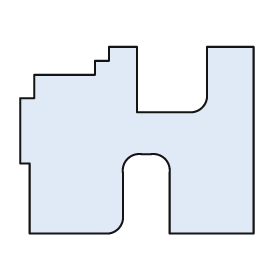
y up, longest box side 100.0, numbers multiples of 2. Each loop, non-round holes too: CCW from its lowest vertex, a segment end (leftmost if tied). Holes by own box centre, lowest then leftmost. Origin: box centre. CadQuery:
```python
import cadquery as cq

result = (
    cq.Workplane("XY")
    .moveTo(-46.0, -40.0)
    .lineTo(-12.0, -40.0)
    .threePointArc((-8.0, -38.0), (-6.0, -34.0))
    .lineTo(-6.0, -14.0)
    .threePointArc((-4.0, -8.0), (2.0, -6.0))
    .lineTo(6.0, -6.0)
    .threePointArc((12.0, -8.0), (14.0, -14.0))
    .lineTo(14.0, -40.0)
    .lineTo(50.0, -40.0)
    .lineTo(50.0, 40.0)
    .lineTo(30.0, 40.0)
    .lineTo(30.0, 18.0)
    .threePointArc((28.0, 14.0), (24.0, 12.0))
    .lineTo(0.0, 12.0)
    .lineTo(0.0, 40.0)
    .lineTo(-12.0, 40.0)
    .lineTo(-12.0, 34.0)
    .lineTo(-18.0, 34.0)
    .lineTo(-18.0, 28.0)
    .lineTo(-44.0, 28.0)
    .lineTo(-44.0, 18.0)
    .lineTo(-50.0, 18.0)
    .lineTo(-50.0, -10.0)
    .lineTo(-46.0, -10.0)
    .close()
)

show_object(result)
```